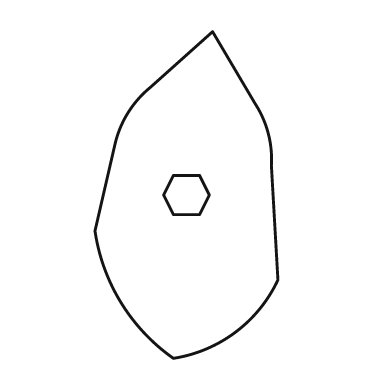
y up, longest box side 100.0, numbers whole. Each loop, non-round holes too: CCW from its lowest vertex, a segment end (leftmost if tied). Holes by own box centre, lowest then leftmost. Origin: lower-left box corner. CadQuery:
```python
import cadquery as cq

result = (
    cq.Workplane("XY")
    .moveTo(24.0, 0.0)
    .threePointArc((43.0, 8.0), (56.0, 24.0))
    .lineTo(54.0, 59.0)
    .threePointArc((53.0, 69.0), (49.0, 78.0))
    .lineTo(36.0, 100.0)
    .lineTo(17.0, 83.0)
    .threePointArc((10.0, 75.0), (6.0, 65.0))
    .lineTo(0.0, 39.0)
    .threePointArc((8.0, 17.0), (24.0, 0.0))
    .close()
    .moveTo(24.0, 44.0)
    .lineTo(32.0, 44.0)
    .lineTo(35.0, 50.0)
    .lineTo(32.0, 56.0)
    .lineTo(24.0, 56.0)
    .lineTo(21.0, 50.0)
    .close()
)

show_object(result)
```